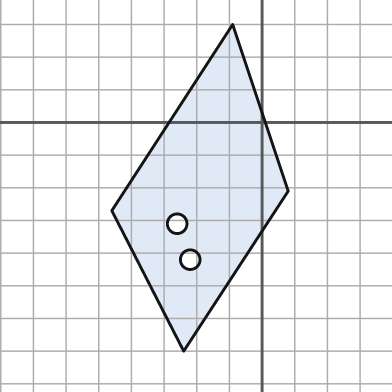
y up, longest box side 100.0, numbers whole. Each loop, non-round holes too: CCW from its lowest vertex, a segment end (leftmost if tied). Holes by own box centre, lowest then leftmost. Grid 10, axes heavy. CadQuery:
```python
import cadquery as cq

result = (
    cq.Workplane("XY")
    .moveTo(-24.0, -70.0)
    .lineTo(8.0, -21.0)
    .lineTo(-9.0, 30.0)
    .lineTo(-46.0, -27.0)
    .close()
    .moveTo(-22.0, -42.0)
    .circle(3.0)
    .moveTo(-26.0, -31.0)
    .circle(3.0)
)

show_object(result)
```